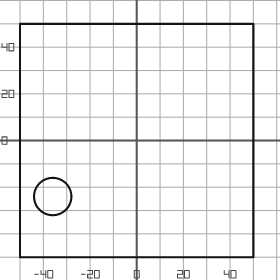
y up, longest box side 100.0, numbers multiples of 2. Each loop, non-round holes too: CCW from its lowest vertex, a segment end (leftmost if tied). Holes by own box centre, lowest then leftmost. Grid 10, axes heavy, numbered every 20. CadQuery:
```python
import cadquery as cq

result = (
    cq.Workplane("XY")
    .moveTo(-50.0, -50.0)
    .lineTo(50.0, -50.0)
    .lineTo(50.0, 50.0)
    .lineTo(-50.0, 50.0)
    .close()
    .moveTo(-36.0, -24.0)
    .circle(8.0)
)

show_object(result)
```